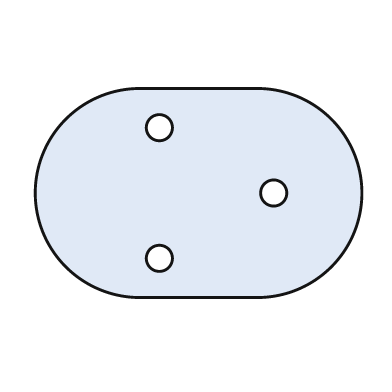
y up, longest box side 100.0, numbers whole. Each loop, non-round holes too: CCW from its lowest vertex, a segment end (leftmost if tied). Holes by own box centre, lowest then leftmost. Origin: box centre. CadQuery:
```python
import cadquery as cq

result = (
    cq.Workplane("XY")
    .moveTo(-18.0, -32.0)
    .lineTo(18.0, -32.0)
    .threePointArc((50.0, 0.0), (18.0, 32.0))
    .lineTo(-18.0, 32.0)
    .threePointArc((-50.0, 0.0), (-18.0, -32.0))
    .close()
    .moveTo(-12.0, -20.0)
    .circle(4.0)
    .moveTo(23.0, 0.0)
    .circle(4.0)
    .moveTo(-12.0, 20.0)
    .circle(4.0)
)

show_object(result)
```